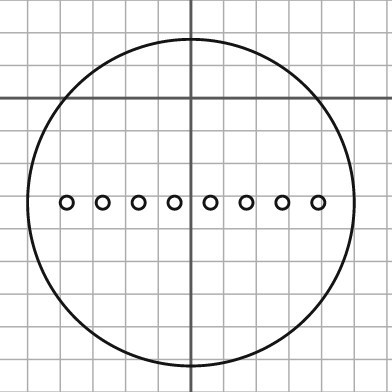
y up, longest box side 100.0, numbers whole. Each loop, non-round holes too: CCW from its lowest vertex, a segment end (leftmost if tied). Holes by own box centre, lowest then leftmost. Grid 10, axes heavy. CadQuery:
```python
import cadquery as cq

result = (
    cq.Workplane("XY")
    .moveTo(0.0, -32.0)
    .circle(50.0)
    .moveTo(-38.0, -32.0)
    .circle(2.0)
    .moveTo(-27.0, -32.0)
    .circle(2.0)
    .moveTo(-16.0, -32.0)
    .circle(2.0)
    .moveTo(-5.0, -32.0)
    .circle(2.0)
    .moveTo(6.0, -32.0)
    .circle(2.0)
    .moveTo(17.0, -32.0)
    .circle(2.0)
    .moveTo(28.0, -32.0)
    .circle(2.0)
    .moveTo(39.0, -32.0)
    .circle(2.0)
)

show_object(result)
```